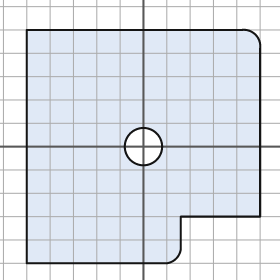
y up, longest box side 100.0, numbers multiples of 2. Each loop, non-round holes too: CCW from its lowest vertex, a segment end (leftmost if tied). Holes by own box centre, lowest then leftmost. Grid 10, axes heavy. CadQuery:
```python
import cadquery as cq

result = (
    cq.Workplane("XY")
    .moveTo(-50.0, -50.0)
    .lineTo(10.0, -50.0)
    .threePointArc((14.0, -48.0), (16.0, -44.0))
    .lineTo(16.0, -30.0)
    .lineTo(50.0, -30.0)
    .lineTo(50.0, 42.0)
    .threePointArc((48.0, 48.0), (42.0, 50.0))
    .lineTo(-50.0, 50.0)
    .close()
    .moveTo(0.0, 0.0)
    .circle(8.0)
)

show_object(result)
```